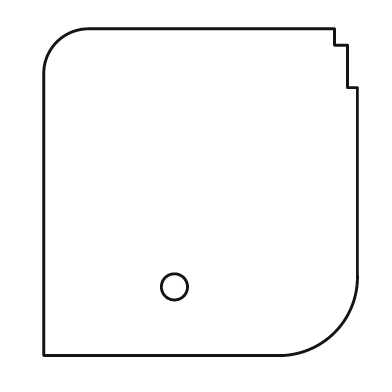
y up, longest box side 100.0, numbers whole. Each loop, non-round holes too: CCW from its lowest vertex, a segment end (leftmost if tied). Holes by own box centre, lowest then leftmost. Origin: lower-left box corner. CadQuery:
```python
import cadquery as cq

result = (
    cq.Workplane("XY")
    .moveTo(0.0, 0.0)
    .lineTo(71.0, 0.0)
    .threePointArc((89.0, 7.0), (96.0, 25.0))
    .lineTo(96.0, 82.0)
    .lineTo(93.0, 82.0)
    .lineTo(93.0, 95.0)
    .lineTo(89.0, 95.0)
    .lineTo(89.0, 100.0)
    .lineTo(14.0, 100.0)
    .threePointArc((4.0, 96.0), (0.0, 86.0))
    .close()
    .moveTo(40.0, 21.0)
    .circle(4.0)
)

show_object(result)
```